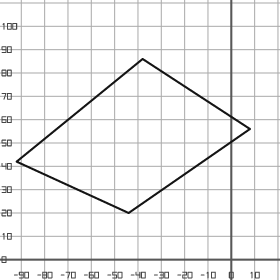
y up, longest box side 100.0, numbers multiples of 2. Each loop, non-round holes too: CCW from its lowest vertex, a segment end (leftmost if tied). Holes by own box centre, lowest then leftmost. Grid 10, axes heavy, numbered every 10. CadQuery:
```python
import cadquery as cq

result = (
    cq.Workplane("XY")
    .moveTo(-44.0, 20.0)
    .lineTo(8.0, 56.0)
    .lineTo(-38.0, 86.0)
    .lineTo(-92.0, 42.0)
    .close()
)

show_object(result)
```